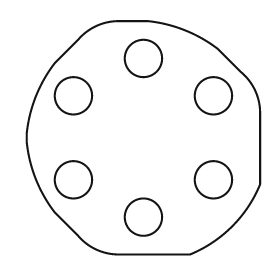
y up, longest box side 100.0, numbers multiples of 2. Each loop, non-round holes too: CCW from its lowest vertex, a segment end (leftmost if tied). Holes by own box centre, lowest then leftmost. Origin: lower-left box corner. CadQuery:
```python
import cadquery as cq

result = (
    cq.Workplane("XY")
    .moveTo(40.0, 0.0)
    .lineTo(70.0, 0.0)
    .threePointArc((88.0, 12.0), (100.0, 30.0))
    .lineTo(100.0, 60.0)
    .threePointArc((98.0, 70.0), (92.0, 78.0))
    .lineTo(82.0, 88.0)
    .threePointArc((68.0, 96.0), (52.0, 100.0))
    .lineTo(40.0, 100.0)
    .threePointArc((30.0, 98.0), (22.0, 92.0))
    .lineTo(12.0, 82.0)
    .threePointArc((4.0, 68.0), (0.0, 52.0))
    .lineTo(0.0, 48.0)
    .threePointArc((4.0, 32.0), (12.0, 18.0))
    .lineTo(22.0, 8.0)
    .threePointArc((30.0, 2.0), (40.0, 0.0))
    .close()
    .moveTo(50.0, 16.0)
    .circle(8.0)
    .moveTo(20.0, 32.0)
    .circle(8.0)
    .moveTo(80.0, 32.0)
    .circle(8.0)
    .moveTo(20.0, 68.0)
    .circle(8.0)
    .moveTo(80.0, 68.0)
    .circle(8.0)
    .moveTo(50.0, 84.0)
    .circle(8.0)
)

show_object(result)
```